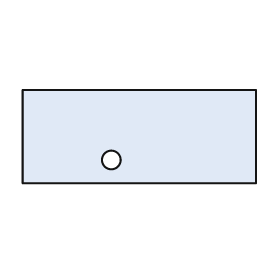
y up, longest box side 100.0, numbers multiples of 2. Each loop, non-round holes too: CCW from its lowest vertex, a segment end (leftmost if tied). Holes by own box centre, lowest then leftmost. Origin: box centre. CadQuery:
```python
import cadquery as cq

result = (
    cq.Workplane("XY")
    .moveTo(-50.0, -20.0)
    .lineTo(50.0, -20.0)
    .lineTo(50.0, 20.0)
    .lineTo(-50.0, 20.0)
    .close()
    .moveTo(-12.0, -10.0)
    .circle(4.0)
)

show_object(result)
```